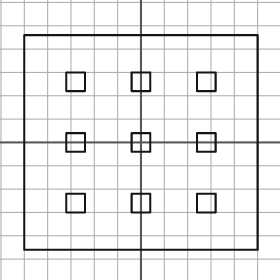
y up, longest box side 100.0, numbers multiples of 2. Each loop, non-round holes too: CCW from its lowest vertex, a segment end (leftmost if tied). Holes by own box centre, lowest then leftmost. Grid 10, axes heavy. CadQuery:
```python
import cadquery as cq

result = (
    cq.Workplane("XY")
    .moveTo(-50.0, -46.0)
    .lineTo(50.0, -46.0)
    .lineTo(50.0, 46.0)
    .lineTo(-50.0, 46.0)
    .close()
    .moveTo(-32.0, -30.0)
    .lineTo(-24.0, -30.0)
    .lineTo(-24.0, -22.0)
    .lineTo(-32.0, -22.0)
    .close()
    .moveTo(-4.0, -30.0)
    .lineTo(4.0, -30.0)
    .lineTo(4.0, -22.0)
    .lineTo(-4.0, -22.0)
    .close()
    .moveTo(24.0, -30.0)
    .lineTo(32.0, -30.0)
    .lineTo(32.0, -22.0)
    .lineTo(24.0, -22.0)
    .close()
    .moveTo(-32.0, -4.0)
    .lineTo(-24.0, -4.0)
    .lineTo(-24.0, 4.0)
    .lineTo(-32.0, 4.0)
    .close()
    .moveTo(-4.0, -4.0)
    .lineTo(4.0, -4.0)
    .lineTo(4.0, 4.0)
    .lineTo(-4.0, 4.0)
    .close()
    .moveTo(24.0, -4.0)
    .lineTo(32.0, -4.0)
    .lineTo(32.0, 4.0)
    .lineTo(24.0, 4.0)
    .close()
    .moveTo(-32.0, 22.0)
    .lineTo(-24.0, 22.0)
    .lineTo(-24.0, 30.0)
    .lineTo(-32.0, 30.0)
    .close()
    .moveTo(-4.0, 22.0)
    .lineTo(4.0, 22.0)
    .lineTo(4.0, 30.0)
    .lineTo(-4.0, 30.0)
    .close()
    .moveTo(24.0, 22.0)
    .lineTo(32.0, 22.0)
    .lineTo(32.0, 30.0)
    .lineTo(24.0, 30.0)
    .close()
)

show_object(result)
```